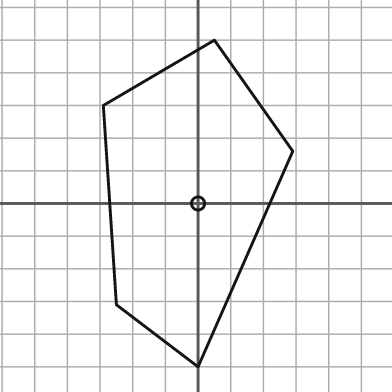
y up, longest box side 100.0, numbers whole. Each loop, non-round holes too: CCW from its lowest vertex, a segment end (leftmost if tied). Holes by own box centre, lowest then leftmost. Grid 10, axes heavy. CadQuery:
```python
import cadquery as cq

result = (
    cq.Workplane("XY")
    .moveTo(0.0, -50.0)
    .lineTo(29.0, 16.0)
    .lineTo(5.0, 50.0)
    .lineTo(-29.0, 30.0)
    .lineTo(-25.0, -31.0)
    .close()
    .moveTo(0.0, 0.0)
    .circle(2.0)
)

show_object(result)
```